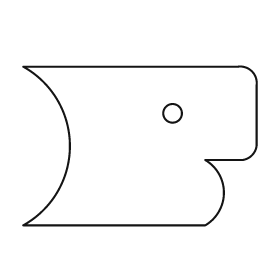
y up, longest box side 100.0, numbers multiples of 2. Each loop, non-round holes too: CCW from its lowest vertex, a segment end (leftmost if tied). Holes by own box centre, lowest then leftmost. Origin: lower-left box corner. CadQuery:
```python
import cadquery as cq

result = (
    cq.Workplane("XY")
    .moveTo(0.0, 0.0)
    .lineTo(78.0, 0.0)
    .threePointArc((86.0, 14.0), (78.0, 28.0))
    .lineTo(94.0, 28.0)
    .threePointArc((98.0, 30.0), (100.0, 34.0))
    .lineTo(100.0, 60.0)
    .threePointArc((98.0, 66.0), (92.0, 68.0))
    .lineTo(0.0, 68.0)
    .threePointArc((20.0, 34.0), (0.0, 0.0))
    .close()
    .moveTo(64.0, 48.0)
    .circle(4.0)
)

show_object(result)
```